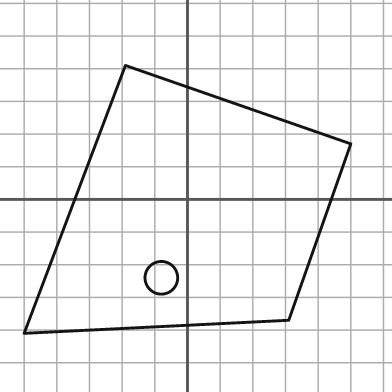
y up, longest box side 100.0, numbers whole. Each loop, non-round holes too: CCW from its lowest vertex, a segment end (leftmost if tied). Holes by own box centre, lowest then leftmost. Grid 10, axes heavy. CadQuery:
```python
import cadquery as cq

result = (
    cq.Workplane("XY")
    .moveTo(-50.0, -41.0)
    .lineTo(31.0, -37.0)
    .lineTo(50.0, 17.0)
    .lineTo(-19.0, 41.0)
    .close()
    .moveTo(-8.0, -24.0)
    .circle(5.0)
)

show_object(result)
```